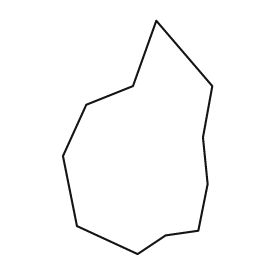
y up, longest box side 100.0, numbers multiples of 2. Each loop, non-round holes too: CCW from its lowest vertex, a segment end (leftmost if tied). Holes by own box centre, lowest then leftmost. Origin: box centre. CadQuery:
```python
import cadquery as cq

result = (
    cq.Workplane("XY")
    .moveTo(0.0, -50.0)
    .lineTo(12.0, -42.0)
    .lineTo(26.0, -40.0)
    .lineTo(30.0, -20.0)
    .lineTo(28.0, 0.0)
    .lineTo(32.0, 22.0)
    .lineTo(8.0, 50.0)
    .lineTo(-2.0, 22.0)
    .lineTo(-22.0, 14.0)
    .lineTo(-32.0, -8.0)
    .lineTo(-26.0, -38.0)
    .close()
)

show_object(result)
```